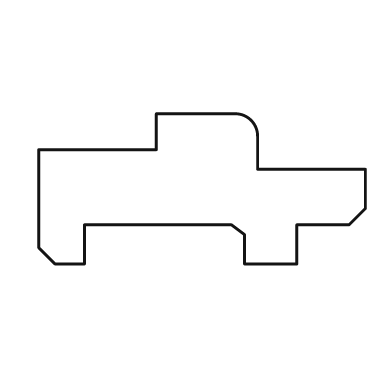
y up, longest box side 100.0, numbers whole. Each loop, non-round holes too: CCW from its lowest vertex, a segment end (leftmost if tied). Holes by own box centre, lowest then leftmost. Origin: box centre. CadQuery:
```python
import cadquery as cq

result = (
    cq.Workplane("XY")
    .moveTo(-45.0, -23.0)
    .lineTo(-36.0, -23.0)
    .lineTo(-36.0, -11.0)
    .lineTo(9.0, -11.0)
    .lineTo(13.0, -14.0)
    .lineTo(13.0, -23.0)
    .lineTo(29.0, -23.0)
    .lineTo(29.0, -11.0)
    .lineTo(45.0, -11.0)
    .lineTo(50.0, -6.0)
    .lineTo(50.0, 6.0)
    .lineTo(17.0, 6.0)
    .lineTo(17.0, 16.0)
    .threePointArc((15.0, 21.0), (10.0, 23.0))
    .lineTo(-14.0, 23.0)
    .lineTo(-14.0, 12.0)
    .lineTo(-50.0, 12.0)
    .lineTo(-50.0, -18.0)
    .close()
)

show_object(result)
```